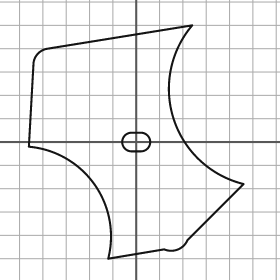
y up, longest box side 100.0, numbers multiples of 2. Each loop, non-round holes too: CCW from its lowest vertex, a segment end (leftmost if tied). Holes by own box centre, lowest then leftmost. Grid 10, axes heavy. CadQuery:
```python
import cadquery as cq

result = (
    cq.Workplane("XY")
    .moveTo(-12.0, -50.0)
    .lineTo(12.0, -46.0)
    .threePointArc((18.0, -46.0), (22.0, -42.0))
    .lineTo(46.0, -18.0)
    .threePointArc((16.0, 10.0), (24.0, 50.0))
    .lineTo(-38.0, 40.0)
    .threePointArc((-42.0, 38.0), (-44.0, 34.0))
    .lineTo(-46.0, -2.0)
    .threePointArc((-18.0, -18.0), (-12.0, -50.0))
    .close()
    .moveTo(-2.0, -4.0)
    .lineTo(2.0, -4.0)
    .threePointArc((6.0, 0.0), (2.0, 4.0))
    .lineTo(-2.0, 4.0)
    .threePointArc((-6.0, 0.0), (-2.0, -4.0))
    .close()
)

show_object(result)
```